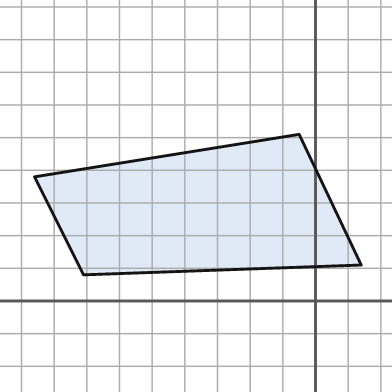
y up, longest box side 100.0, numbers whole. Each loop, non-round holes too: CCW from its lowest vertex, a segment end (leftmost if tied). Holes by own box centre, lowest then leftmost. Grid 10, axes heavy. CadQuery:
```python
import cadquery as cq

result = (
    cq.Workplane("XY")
    .moveTo(-71.0, 8.0)
    .lineTo(14.0, 11.0)
    .lineTo(-5.0, 51.0)
    .lineTo(-86.0, 38.0)
    .close()
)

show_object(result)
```